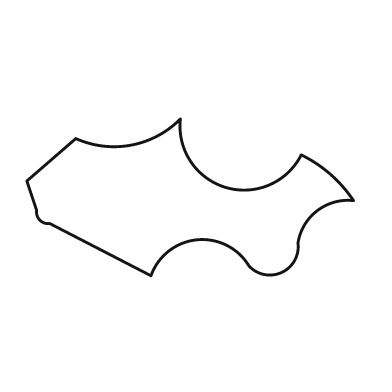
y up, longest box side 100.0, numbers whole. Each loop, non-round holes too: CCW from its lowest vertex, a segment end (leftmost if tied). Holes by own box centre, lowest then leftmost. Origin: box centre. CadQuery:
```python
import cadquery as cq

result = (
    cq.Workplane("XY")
    .moveTo(-12.0, -24.0)
    .threePointArc((2.0, -13.0), (18.0, -21.0))
    .threePointArc((28.0, -23.0), (33.0, -14.0))
    .threePointArc((39.0, -4.0), (50.0, -1.0))
    .threePointArc((43.0, 7.0), (34.0, 13.0))
    .threePointArc((11.0, 3.0), (-3.0, 24.0))
    .threePointArc((-18.0, 16.0), (-35.0, 18.0))
    .lineTo(-50.0, 5.0)
    .lineTo(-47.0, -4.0)
    .threePointArc((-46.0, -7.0), (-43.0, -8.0))
    .close()
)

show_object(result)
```